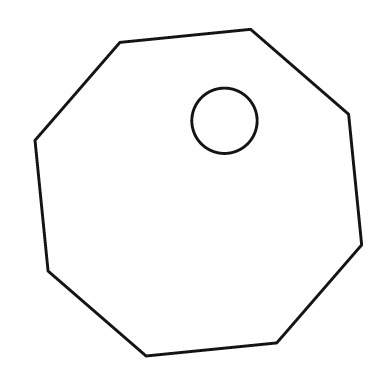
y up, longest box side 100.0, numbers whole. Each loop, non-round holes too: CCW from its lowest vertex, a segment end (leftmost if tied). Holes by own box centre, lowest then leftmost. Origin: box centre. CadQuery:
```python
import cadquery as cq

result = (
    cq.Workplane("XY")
    .moveTo(-16.0, -50.0)
    .lineTo(24.0, -46.0)
    .lineTo(50.0, -16.0)
    .lineTo(46.0, 24.0)
    .lineTo(16.0, 50.0)
    .lineTo(-24.0, 46.0)
    .lineTo(-50.0, 16.0)
    .lineTo(-46.0, -24.0)
    .close()
    .moveTo(8.0, 22.0)
    .circle(10.0)
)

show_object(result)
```